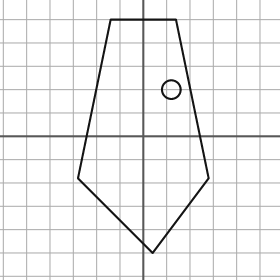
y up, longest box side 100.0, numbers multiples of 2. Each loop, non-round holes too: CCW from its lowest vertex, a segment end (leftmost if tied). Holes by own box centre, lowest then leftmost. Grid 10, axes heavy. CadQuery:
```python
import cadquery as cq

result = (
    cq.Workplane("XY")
    .moveTo(4.0, -50.0)
    .lineTo(28.0, -18.0)
    .lineTo(14.0, 50.0)
    .lineTo(-14.0, 50.0)
    .lineTo(-28.0, -18.0)
    .close()
    .moveTo(12.0, 20.0)
    .circle(4.0)
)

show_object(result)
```